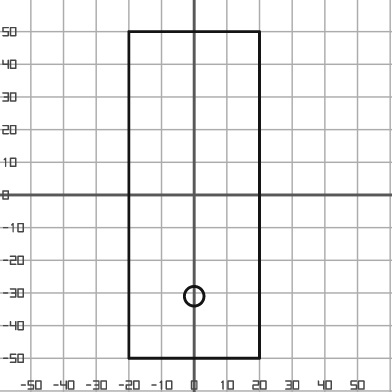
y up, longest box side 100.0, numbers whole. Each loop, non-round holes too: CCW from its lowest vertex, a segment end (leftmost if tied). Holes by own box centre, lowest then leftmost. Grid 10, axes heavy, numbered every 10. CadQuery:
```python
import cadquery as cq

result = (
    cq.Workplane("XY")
    .moveTo(-20.0, -50.0)
    .lineTo(20.0, -50.0)
    .lineTo(20.0, 50.0)
    .lineTo(-20.0, 50.0)
    .close()
    .moveTo(0.0, -31.0)
    .circle(3.0)
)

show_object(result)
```